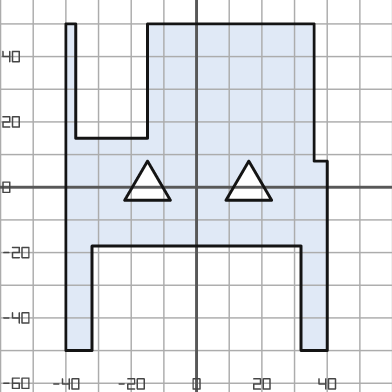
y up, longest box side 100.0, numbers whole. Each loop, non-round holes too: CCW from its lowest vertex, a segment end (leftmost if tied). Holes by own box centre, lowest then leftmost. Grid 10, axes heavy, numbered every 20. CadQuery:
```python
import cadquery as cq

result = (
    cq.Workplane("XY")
    .moveTo(-40.0, -50.0)
    .lineTo(-32.0, -50.0)
    .lineTo(-32.0, -18.0)
    .lineTo(32.0, -18.0)
    .lineTo(32.0, -50.0)
    .lineTo(40.0, -50.0)
    .lineTo(40.0, 8.0)
    .lineTo(36.0, 8.0)
    .lineTo(36.0, 50.0)
    .lineTo(-15.0, 50.0)
    .lineTo(-15.0, 15.0)
    .lineTo(-37.0, 15.0)
    .lineTo(-37.0, 50.0)
    .lineTo(-40.0, 50.0)
    .close()
    .moveTo(-22.0, -4.0)
    .lineTo(-8.0, -4.0)
    .lineTo(-15.0, 8.0)
    .close()
    .moveTo(9.0, -4.0)
    .lineTo(23.0, -4.0)
    .lineTo(16.0, 8.0)
    .close()
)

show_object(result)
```